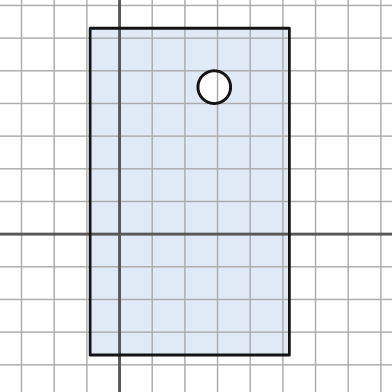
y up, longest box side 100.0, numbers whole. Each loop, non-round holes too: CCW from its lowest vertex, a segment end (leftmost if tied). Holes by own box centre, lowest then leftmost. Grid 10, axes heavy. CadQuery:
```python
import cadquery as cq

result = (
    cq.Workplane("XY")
    .moveTo(-9.0, -37.0)
    .lineTo(52.0, -37.0)
    .lineTo(52.0, 63.0)
    .lineTo(-9.0, 63.0)
    .close()
    .moveTo(29.0, 45.0)
    .circle(5.0)
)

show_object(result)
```